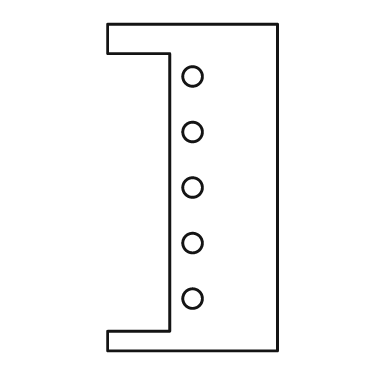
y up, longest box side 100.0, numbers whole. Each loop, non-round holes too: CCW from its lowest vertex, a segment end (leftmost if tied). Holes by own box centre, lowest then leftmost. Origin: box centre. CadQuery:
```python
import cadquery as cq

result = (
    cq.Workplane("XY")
    .moveTo(-26.0, -50.0)
    .lineTo(26.0, -50.0)
    .lineTo(26.0, 50.0)
    .lineTo(-26.0, 50.0)
    .lineTo(-26.0, 41.0)
    .lineTo(-7.0, 41.0)
    .lineTo(-7.0, -44.0)
    .lineTo(-26.0, -44.0)
    .close()
    .moveTo(0.0, -34.0)
    .circle(3.0)
    .moveTo(0.0, -17.0)
    .circle(3.0)
    .moveTo(0.0, 0.0)
    .circle(3.0)
    .moveTo(0.0, 17.0)
    .circle(3.0)
    .moveTo(0.0, 34.0)
    .circle(3.0)
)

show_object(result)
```